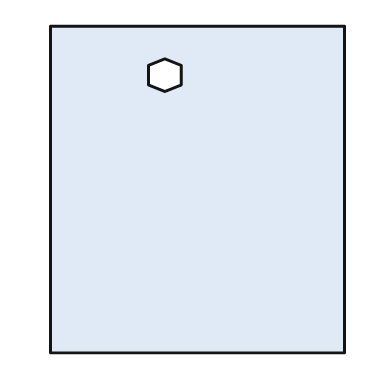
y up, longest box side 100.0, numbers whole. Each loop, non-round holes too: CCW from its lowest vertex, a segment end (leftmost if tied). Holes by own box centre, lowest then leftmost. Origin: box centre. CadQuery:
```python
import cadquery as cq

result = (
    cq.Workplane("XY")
    .moveTo(-45.0, -50.0)
    .lineTo(45.0, -50.0)
    .lineTo(45.0, 50.0)
    .lineTo(-45.0, 50.0)
    .close()
    .moveTo(-10.0, 30.0)
    .lineTo(-5.0, 32.0)
    .lineTo(-5.0, 38.0)
    .lineTo(-10.0, 40.0)
    .lineTo(-15.0, 38.0)
    .lineTo(-15.0, 32.0)
    .close()
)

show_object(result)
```